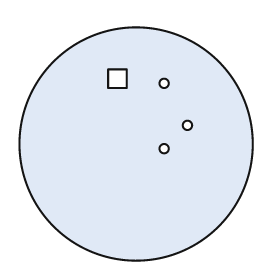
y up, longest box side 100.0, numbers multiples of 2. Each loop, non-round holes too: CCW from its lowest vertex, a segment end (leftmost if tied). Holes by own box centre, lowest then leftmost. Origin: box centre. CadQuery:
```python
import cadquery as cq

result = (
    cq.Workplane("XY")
    .moveTo(0.0, 0.0)
    .circle(50.0)
    .moveTo(12.0, -2.0)
    .circle(2.0)
    .moveTo(22.0, 8.0)
    .circle(2.0)
    .moveTo(12.0, 26.0)
    .circle(2.0)
    .moveTo(-12.0, 24.0)
    .lineTo(-4.0, 24.0)
    .lineTo(-4.0, 32.0)
    .lineTo(-12.0, 32.0)
    .close()
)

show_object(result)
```